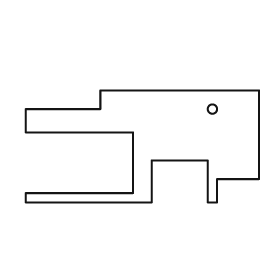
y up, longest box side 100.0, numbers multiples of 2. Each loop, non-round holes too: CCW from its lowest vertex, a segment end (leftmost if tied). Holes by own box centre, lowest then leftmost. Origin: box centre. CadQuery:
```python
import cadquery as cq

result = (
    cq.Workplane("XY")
    .moveTo(-50.0, -24.0)
    .lineTo(4.0, -24.0)
    .lineTo(4.0, -6.0)
    .lineTo(28.0, -6.0)
    .lineTo(28.0, -24.0)
    .lineTo(32.0, -24.0)
    .lineTo(32.0, -14.0)
    .lineTo(50.0, -14.0)
    .lineTo(50.0, 24.0)
    .lineTo(-18.0, 24.0)
    .lineTo(-18.0, 16.0)
    .lineTo(-50.0, 16.0)
    .lineTo(-50.0, 6.0)
    .lineTo(-4.0, 6.0)
    .lineTo(-4.0, -20.0)
    .lineTo(-50.0, -20.0)
    .close()
    .moveTo(30.0, 16.0)
    .circle(2.0)
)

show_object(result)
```